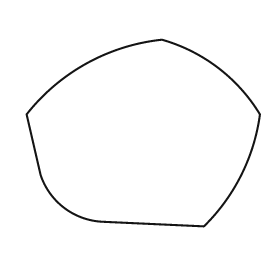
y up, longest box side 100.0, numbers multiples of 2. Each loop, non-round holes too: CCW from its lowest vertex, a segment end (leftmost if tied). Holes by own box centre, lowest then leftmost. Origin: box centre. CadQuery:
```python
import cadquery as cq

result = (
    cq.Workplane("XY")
    .moveTo(26.0, -40.0)
    .threePointArc((42.0, -18.0), (50.0, 8.0))
    .threePointArc((32.0, 28.0), (8.0, 40.0))
    .threePointArc((-24.0, 30.0), (-50.0, 8.0))
    .lineTo(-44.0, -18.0)
    .threePointArc((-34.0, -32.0), (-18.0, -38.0))
    .close()
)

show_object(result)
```